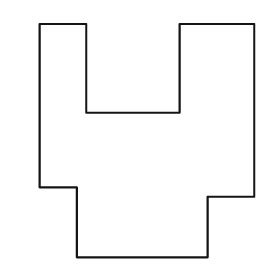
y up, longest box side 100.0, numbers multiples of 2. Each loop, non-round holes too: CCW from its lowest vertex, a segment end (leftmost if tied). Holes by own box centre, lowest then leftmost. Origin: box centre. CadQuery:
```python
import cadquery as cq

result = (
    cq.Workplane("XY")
    .moveTo(-30.0, -50.0)
    .lineTo(26.0, -50.0)
    .lineTo(26.0, -24.0)
    .lineTo(46.0, -24.0)
    .lineTo(46.0, 50.0)
    .lineTo(14.0, 50.0)
    .lineTo(14.0, 12.0)
    .lineTo(-26.0, 12.0)
    .lineTo(-26.0, 50.0)
    .lineTo(-46.0, 50.0)
    .lineTo(-46.0, -20.0)
    .lineTo(-30.0, -20.0)
    .close()
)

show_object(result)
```